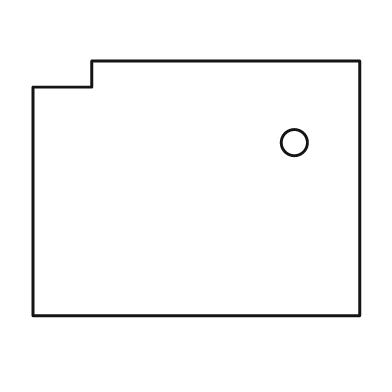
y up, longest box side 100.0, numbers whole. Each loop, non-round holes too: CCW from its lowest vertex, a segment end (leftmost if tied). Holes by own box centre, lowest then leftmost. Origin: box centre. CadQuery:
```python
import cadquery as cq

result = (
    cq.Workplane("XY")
    .moveTo(-50.0, -39.0)
    .lineTo(50.0, -39.0)
    .lineTo(50.0, 39.0)
    .lineTo(-32.0, 39.0)
    .lineTo(-32.0, 31.0)
    .lineTo(-50.0, 31.0)
    .close()
    .moveTo(30.0, 14.0)
    .circle(4.0)
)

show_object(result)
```